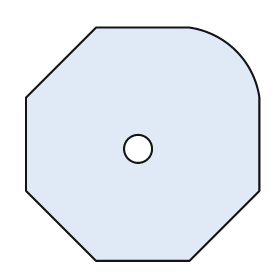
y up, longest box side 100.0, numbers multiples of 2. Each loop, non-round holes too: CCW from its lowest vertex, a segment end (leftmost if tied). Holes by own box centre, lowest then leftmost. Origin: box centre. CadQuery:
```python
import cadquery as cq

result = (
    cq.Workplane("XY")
    .moveTo(-20.0, -50.0)
    .lineTo(20.0, -50.0)
    .lineTo(50.0, -20.0)
    .lineTo(50.0, 20.0)
    .threePointArc((40.0, 40.0), (20.0, 50.0))
    .lineTo(-20.0, 50.0)
    .lineTo(-50.0, 20.0)
    .lineTo(-50.0, -20.0)
    .close()
    .moveTo(-2.0, -2.0)
    .circle(6.0)
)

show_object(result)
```